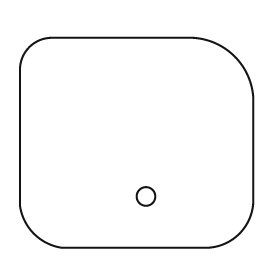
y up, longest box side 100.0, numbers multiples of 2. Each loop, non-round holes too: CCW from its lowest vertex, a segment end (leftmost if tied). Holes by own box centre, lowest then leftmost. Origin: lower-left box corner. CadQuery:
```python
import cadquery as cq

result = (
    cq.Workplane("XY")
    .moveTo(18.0, 0.0)
    .lineTo(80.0, 0.0)
    .threePointArc((94.0, 6.0), (100.0, 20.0))
    .lineTo(100.0, 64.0)
    .threePointArc((92.0, 82.0), (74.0, 90.0))
    .lineTo(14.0, 90.0)
    .threePointArc((4.0, 86.0), (0.0, 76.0))
    .lineTo(0.0, 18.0)
    .threePointArc((6.0, 6.0), (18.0, 0.0))
    .close()
    .moveTo(54.0, 22.0)
    .circle(4.0)
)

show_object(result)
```